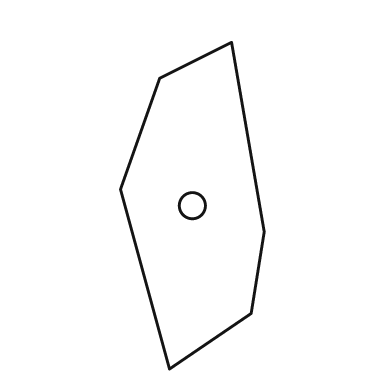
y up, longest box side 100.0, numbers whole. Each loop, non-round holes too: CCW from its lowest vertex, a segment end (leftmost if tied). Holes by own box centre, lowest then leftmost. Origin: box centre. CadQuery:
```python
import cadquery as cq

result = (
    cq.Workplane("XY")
    .moveTo(-7.0, -50.0)
    .lineTo(18.0, -33.0)
    .lineTo(22.0, -8.0)
    .lineTo(12.0, 50.0)
    .lineTo(-10.0, 39.0)
    .lineTo(-22.0, 5.0)
    .close()
    .moveTo(0.0, 0.0)
    .circle(4.0)
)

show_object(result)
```